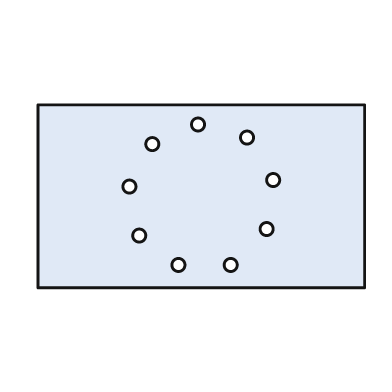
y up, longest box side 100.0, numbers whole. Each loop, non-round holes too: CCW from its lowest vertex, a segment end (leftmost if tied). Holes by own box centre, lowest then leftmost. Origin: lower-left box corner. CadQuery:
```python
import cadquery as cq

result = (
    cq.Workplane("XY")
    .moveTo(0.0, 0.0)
    .lineTo(100.0, 0.0)
    .lineTo(100.0, 56.0)
    .lineTo(0.0, 56.0)
    .close()
    .moveTo(43.0, 7.0)
    .circle(2.0)
    .moveTo(59.0, 7.0)
    .circle(2.0)
    .moveTo(31.0, 16.0)
    .circle(2.0)
    .moveTo(70.0, 18.0)
    .circle(2.0)
    .moveTo(28.0, 31.0)
    .circle(2.0)
    .moveTo(72.0, 33.0)
    .circle(2.0)
    .moveTo(35.0, 44.0)
    .circle(2.0)
    .moveTo(64.0, 46.0)
    .circle(2.0)
    .moveTo(49.0, 50.0)
    .circle(2.0)
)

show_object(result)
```